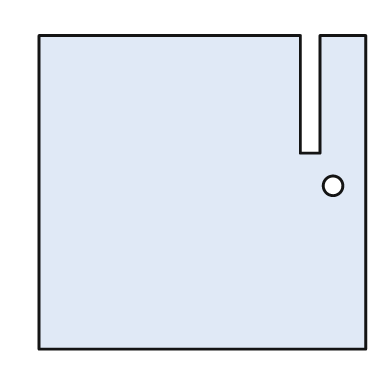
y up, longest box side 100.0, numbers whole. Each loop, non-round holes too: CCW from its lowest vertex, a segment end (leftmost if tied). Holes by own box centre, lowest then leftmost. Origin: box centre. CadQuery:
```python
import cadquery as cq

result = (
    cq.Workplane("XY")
    .moveTo(-50.0, -48.0)
    .lineTo(50.0, -48.0)
    .lineTo(50.0, 48.0)
    .lineTo(36.0, 48.0)
    .lineTo(36.0, 12.0)
    .lineTo(30.0, 12.0)
    .lineTo(30.0, 48.0)
    .lineTo(-50.0, 48.0)
    .close()
    .moveTo(40.0, 2.0)
    .circle(3.0)
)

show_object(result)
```